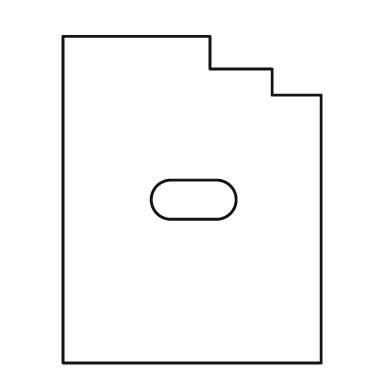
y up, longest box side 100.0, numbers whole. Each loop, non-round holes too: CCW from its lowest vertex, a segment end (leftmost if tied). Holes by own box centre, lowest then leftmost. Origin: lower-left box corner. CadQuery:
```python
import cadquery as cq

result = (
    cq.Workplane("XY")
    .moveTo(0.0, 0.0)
    .lineTo(79.0, 0.0)
    .lineTo(79.0, 82.0)
    .lineTo(64.0, 82.0)
    .lineTo(64.0, 90.0)
    .lineTo(45.0, 90.0)
    .lineTo(45.0, 100.0)
    .lineTo(0.0, 100.0)
    .close()
    .moveTo(33.0, 44.0)
    .lineTo(47.0, 44.0)
    .threePointArc((53.0, 50.0), (47.0, 56.0))
    .lineTo(33.0, 56.0)
    .threePointArc((27.0, 50.0), (33.0, 44.0))
    .close()
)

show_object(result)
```